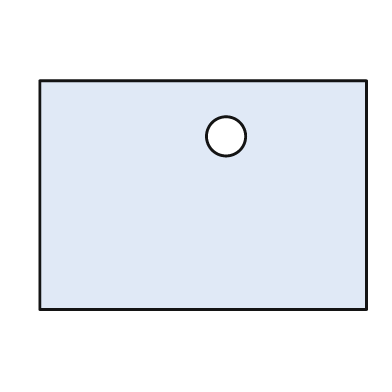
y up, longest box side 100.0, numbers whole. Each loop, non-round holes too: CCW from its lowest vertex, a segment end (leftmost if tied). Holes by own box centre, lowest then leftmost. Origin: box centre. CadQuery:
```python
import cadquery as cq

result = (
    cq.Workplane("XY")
    .moveTo(-50.0, -35.0)
    .lineTo(50.0, -35.0)
    .lineTo(50.0, 35.0)
    .lineTo(-50.0, 35.0)
    .close()
    .moveTo(7.0, 18.0)
    .circle(6.0)
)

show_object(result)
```